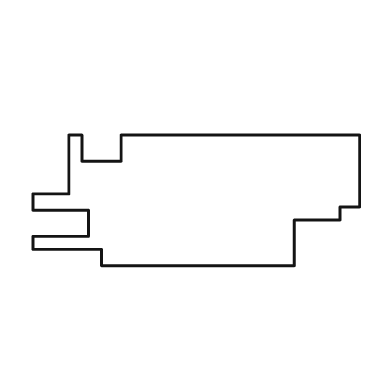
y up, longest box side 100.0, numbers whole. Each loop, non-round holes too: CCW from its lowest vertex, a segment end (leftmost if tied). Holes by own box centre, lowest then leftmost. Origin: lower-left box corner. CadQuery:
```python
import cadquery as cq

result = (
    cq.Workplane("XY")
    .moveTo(21.0, 0.0)
    .lineTo(80.0, 0.0)
    .lineTo(80.0, 14.0)
    .lineTo(94.0, 14.0)
    .lineTo(94.0, 18.0)
    .lineTo(100.0, 18.0)
    .lineTo(100.0, 40.0)
    .lineTo(27.0, 40.0)
    .lineTo(27.0, 32.0)
    .lineTo(15.0, 32.0)
    .lineTo(15.0, 40.0)
    .lineTo(11.0, 40.0)
    .lineTo(11.0, 22.0)
    .lineTo(0.0, 22.0)
    .lineTo(0.0, 17.0)
    .lineTo(17.0, 17.0)
    .lineTo(17.0, 9.0)
    .lineTo(0.0, 9.0)
    .lineTo(0.0, 5.0)
    .lineTo(21.0, 5.0)
    .close()
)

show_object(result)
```